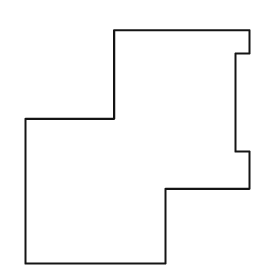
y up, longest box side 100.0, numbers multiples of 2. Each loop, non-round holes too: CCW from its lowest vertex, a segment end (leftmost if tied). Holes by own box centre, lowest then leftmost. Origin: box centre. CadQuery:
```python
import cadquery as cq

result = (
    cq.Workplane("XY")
    .moveTo(-48.0, -50.0)
    .lineTo(12.0, -50.0)
    .lineTo(12.0, -18.0)
    .lineTo(48.0, -18.0)
    .lineTo(48.0, -2.0)
    .lineTo(42.0, -2.0)
    .lineTo(42.0, 40.0)
    .lineTo(48.0, 40.0)
    .lineTo(48.0, 50.0)
    .lineTo(-10.0, 50.0)
    .lineTo(-10.0, 12.0)
    .lineTo(-48.0, 12.0)
    .close()
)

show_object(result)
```